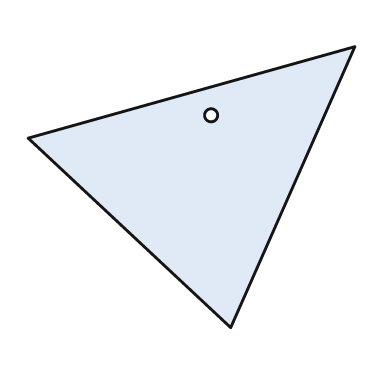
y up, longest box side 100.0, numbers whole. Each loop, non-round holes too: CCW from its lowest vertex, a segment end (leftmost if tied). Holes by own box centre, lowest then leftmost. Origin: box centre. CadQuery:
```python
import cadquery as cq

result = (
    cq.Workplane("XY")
    .moveTo(12.0, -43.0)
    .lineTo(50.0, 43.0)
    .lineTo(-50.0, 15.0)
    .close()
    .moveTo(6.0, 22.0)
    .circle(2.0)
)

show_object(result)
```